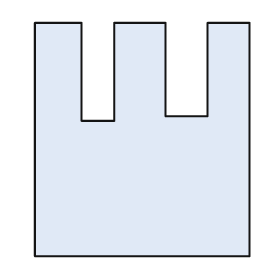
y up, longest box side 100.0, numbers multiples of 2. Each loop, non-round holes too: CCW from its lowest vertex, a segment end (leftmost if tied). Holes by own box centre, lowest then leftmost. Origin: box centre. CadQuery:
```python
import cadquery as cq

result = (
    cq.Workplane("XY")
    .moveTo(-46.0, -50.0)
    .lineTo(46.0, -50.0)
    .lineTo(46.0, 50.0)
    .lineTo(28.0, 50.0)
    .lineTo(28.0, 10.0)
    .lineTo(10.0, 10.0)
    .lineTo(10.0, 50.0)
    .lineTo(-12.0, 50.0)
    .lineTo(-12.0, 8.0)
    .lineTo(-26.0, 8.0)
    .lineTo(-26.0, 50.0)
    .lineTo(-46.0, 50.0)
    .close()
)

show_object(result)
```